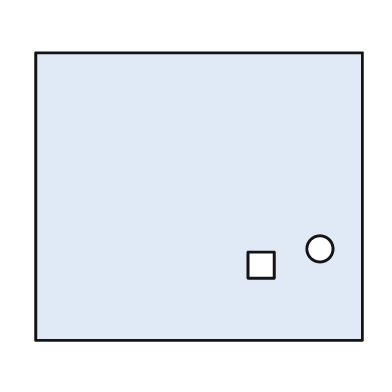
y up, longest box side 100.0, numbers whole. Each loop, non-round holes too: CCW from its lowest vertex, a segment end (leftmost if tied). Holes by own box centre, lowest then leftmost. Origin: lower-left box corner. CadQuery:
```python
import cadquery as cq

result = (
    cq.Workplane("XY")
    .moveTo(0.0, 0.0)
    .lineTo(100.0, 0.0)
    .lineTo(100.0, 88.0)
    .lineTo(0.0, 88.0)
    .close()
    .moveTo(65.0, 19.0)
    .lineTo(73.0, 19.0)
    .lineTo(73.0, 27.0)
    .lineTo(65.0, 27.0)
    .close()
    .moveTo(87.0, 28.0)
    .circle(4.0)
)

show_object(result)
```